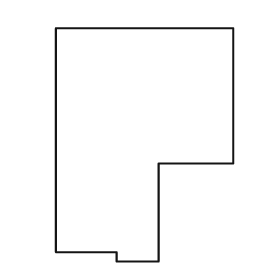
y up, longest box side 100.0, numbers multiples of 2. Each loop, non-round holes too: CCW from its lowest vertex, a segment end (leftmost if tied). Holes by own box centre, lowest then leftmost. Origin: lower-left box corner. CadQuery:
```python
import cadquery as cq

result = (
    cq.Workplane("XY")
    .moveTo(26.0, 0.0)
    .lineTo(44.0, 0.0)
    .lineTo(44.0, 42.0)
    .lineTo(76.0, 42.0)
    .lineTo(76.0, 100.0)
    .lineTo(0.0, 100.0)
    .lineTo(0.0, 4.0)
    .lineTo(26.0, 4.0)
    .close()
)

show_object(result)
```